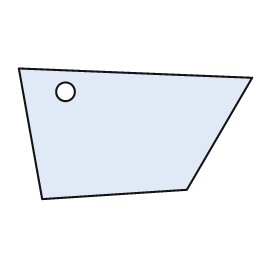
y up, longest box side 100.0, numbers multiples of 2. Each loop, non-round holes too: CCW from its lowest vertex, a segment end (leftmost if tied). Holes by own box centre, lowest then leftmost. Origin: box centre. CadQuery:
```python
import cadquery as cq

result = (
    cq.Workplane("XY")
    .moveTo(-40.0, -28.0)
    .lineTo(22.0, -24.0)
    .lineTo(50.0, 24.0)
    .lineTo(-50.0, 28.0)
    .close()
    .moveTo(-30.0, 18.0)
    .circle(4.0)
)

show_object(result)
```